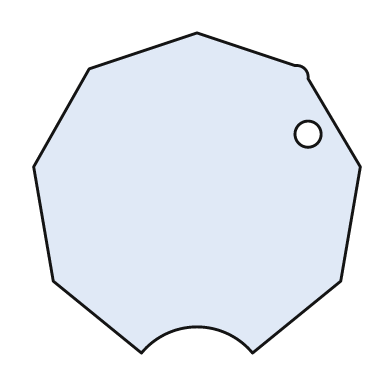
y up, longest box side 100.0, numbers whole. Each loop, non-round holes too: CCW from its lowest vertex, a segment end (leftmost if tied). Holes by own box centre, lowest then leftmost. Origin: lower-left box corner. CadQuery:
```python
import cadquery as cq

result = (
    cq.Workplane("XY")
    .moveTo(33.0, 0.0)
    .threePointArc((50.0, 8.0), (67.0, 0.0))
    .lineTo(94.0, 22.0)
    .lineTo(100.0, 57.0)
    .lineTo(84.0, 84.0)
    .threePointArc((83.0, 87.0), (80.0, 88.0))
    .lineTo(50.0, 98.0)
    .lineTo(17.0, 87.0)
    .lineTo(0.0, 57.0)
    .lineTo(6.0, 22.0)
    .close()
    .moveTo(84.0, 67.0)
    .circle(4.0)
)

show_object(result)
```